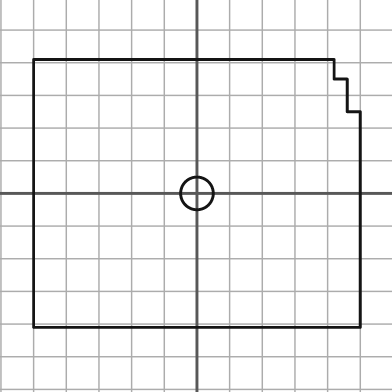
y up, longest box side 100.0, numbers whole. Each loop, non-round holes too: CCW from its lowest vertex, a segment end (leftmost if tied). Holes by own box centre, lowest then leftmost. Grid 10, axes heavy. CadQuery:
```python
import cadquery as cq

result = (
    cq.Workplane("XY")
    .moveTo(-50.0, -41.0)
    .lineTo(50.0, -41.0)
    .lineTo(50.0, 25.0)
    .lineTo(46.0, 25.0)
    .lineTo(46.0, 35.0)
    .lineTo(42.0, 35.0)
    .lineTo(42.0, 41.0)
    .lineTo(-50.0, 41.0)
    .close()
    .moveTo(0.0, 0.0)
    .circle(5.0)
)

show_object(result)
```